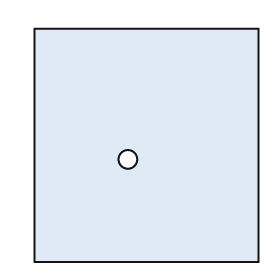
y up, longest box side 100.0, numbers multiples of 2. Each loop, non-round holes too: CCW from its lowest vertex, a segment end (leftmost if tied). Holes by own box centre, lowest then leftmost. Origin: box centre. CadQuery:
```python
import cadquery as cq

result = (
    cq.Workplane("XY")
    .moveTo(-48.0, -50.0)
    .lineTo(48.0, -50.0)
    .lineTo(48.0, 50.0)
    .lineTo(-48.0, 50.0)
    .close()
    .moveTo(-8.0, -6.0)
    .circle(4.0)
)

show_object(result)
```